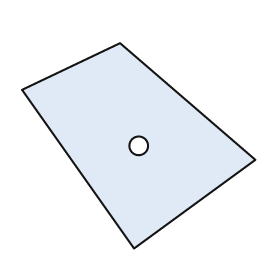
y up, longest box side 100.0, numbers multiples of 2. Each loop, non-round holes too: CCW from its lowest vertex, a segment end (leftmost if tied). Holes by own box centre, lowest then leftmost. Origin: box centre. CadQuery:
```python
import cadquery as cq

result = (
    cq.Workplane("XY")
    .moveTo(-2.0, -44.0)
    .lineTo(50.0, -6.0)
    .lineTo(-8.0, 44.0)
    .lineTo(-50.0, 24.0)
    .close()
    .moveTo(0.0, 0.0)
    .circle(4.0)
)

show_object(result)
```